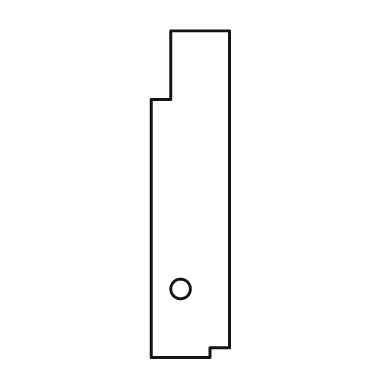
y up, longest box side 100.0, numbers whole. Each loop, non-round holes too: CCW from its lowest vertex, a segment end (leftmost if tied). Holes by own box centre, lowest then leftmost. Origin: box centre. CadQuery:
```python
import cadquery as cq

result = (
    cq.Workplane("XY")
    .moveTo(-12.0, -50.0)
    .lineTo(6.0, -50.0)
    .lineTo(6.0, -47.0)
    .lineTo(12.0, -47.0)
    .lineTo(12.0, 50.0)
    .lineTo(-6.0, 50.0)
    .lineTo(-6.0, 29.0)
    .lineTo(-12.0, 29.0)
    .close()
    .moveTo(-3.0, -29.0)
    .circle(3.0)
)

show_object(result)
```